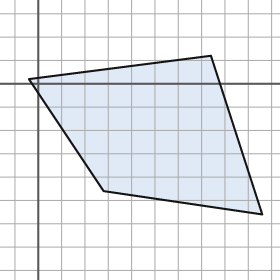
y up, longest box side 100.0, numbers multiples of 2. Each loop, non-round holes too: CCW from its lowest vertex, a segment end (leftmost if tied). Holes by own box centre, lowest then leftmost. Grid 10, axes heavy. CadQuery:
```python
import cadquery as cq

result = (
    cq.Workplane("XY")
    .moveTo(96.0, -56.0)
    .lineTo(74.0, 12.0)
    .lineTo(-4.0, 2.0)
    .lineTo(28.0, -46.0)
    .close()
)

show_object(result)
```